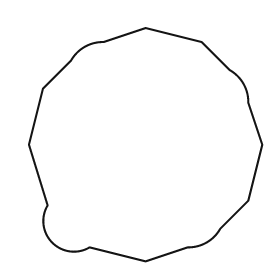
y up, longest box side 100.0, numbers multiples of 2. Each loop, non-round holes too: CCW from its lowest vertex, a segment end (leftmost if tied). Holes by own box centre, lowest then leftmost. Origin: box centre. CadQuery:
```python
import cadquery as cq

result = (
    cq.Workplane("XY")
    .moveTo(0.0, -50.0)
    .lineTo(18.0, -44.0)
    .threePointArc((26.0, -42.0), (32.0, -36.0))
    .lineTo(44.0, -24.0)
    .lineTo(50.0, 0.0)
    .lineTo(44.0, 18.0)
    .threePointArc((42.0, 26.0), (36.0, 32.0))
    .lineTo(24.0, 44.0)
    .lineTo(0.0, 50.0)
    .lineTo(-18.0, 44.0)
    .threePointArc((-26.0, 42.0), (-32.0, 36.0))
    .lineTo(-44.0, 24.0)
    .lineTo(-50.0, 0.0)
    .lineTo(-42.0, -26.0)
    .threePointArc((-40.0, -42.0), (-24.0, -44.0))
    .close()
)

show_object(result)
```